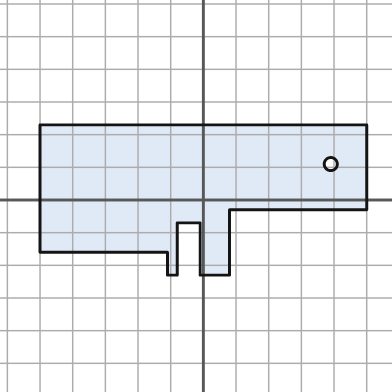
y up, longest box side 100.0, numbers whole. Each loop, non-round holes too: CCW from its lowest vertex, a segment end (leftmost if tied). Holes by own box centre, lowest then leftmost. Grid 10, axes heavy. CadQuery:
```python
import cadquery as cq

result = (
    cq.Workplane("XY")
    .moveTo(-11.0, -23.0)
    .lineTo(-8.0, -23.0)
    .lineTo(-8.0, -7.0)
    .lineTo(-1.0, -7.0)
    .lineTo(-1.0, -23.0)
    .lineTo(8.0, -23.0)
    .lineTo(8.0, -3.0)
    .lineTo(50.0, -3.0)
    .lineTo(50.0, 23.0)
    .lineTo(-50.0, 23.0)
    .lineTo(-50.0, -16.0)
    .lineTo(-11.0, -16.0)
    .close()
    .moveTo(39.0, 11.0)
    .circle(2.0)
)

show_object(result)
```